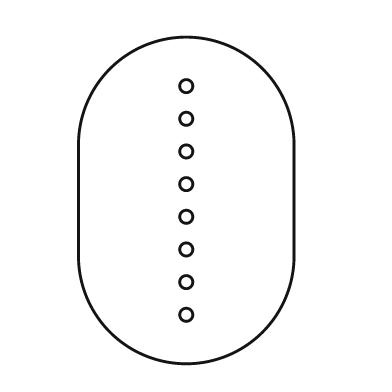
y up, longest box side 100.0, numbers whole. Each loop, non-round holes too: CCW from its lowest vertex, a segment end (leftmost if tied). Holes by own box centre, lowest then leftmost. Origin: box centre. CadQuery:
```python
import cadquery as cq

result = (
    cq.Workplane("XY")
    .moveTo(-33.0, -17.0)
    .threePointArc((0.0, -50.0), (33.0, -17.0))
    .lineTo(33.0, 17.0)
    .threePointArc((0.0, 50.0), (-33.0, 17.0))
    .close()
    .moveTo(0.0, -35.0)
    .circle(2.0)
    .moveTo(0.0, -25.0)
    .circle(2.0)
    .moveTo(0.0, -15.0)
    .circle(2.0)
    .moveTo(0.0, -5.0)
    .circle(2.0)
    .moveTo(0.0, 5.0)
    .circle(2.0)
    .moveTo(0.0, 15.0)
    .circle(2.0)
    .moveTo(0.0, 25.0)
    .circle(2.0)
    .moveTo(0.0, 35.0)
    .circle(2.0)
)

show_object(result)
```